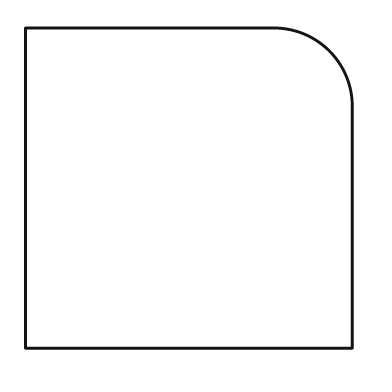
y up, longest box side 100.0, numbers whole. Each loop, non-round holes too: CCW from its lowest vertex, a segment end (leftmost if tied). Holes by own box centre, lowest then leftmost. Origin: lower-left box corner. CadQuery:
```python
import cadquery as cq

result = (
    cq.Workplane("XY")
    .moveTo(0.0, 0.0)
    .lineTo(100.0, 0.0)
    .lineTo(100.0, 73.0)
    .threePointArc((93.0, 91.0), (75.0, 98.0))
    .lineTo(0.0, 98.0)
    .close()
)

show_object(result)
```